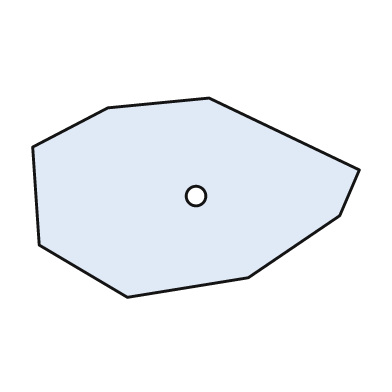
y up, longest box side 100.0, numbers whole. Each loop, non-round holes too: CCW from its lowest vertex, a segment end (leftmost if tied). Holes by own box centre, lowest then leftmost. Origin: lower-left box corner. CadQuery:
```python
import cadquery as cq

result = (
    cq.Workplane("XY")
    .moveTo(29.0, 0.0)
    .lineTo(66.0, 6.0)
    .lineTo(94.0, 25.0)
    .lineTo(100.0, 39.0)
    .lineTo(54.0, 61.0)
    .lineTo(23.0, 58.0)
    .lineTo(0.0, 46.0)
    .lineTo(2.0, 16.0)
    .close()
    .moveTo(50.0, 31.0)
    .circle(3.0)
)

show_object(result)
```